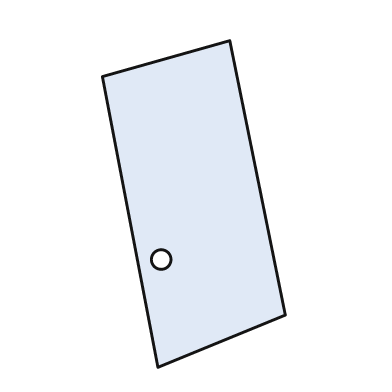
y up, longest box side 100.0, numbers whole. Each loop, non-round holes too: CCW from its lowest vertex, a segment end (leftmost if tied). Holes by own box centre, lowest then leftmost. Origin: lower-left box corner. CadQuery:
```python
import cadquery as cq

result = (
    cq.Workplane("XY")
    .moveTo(17.0, 0.0)
    .lineTo(56.0, 16.0)
    .lineTo(39.0, 100.0)
    .lineTo(0.0, 89.0)
    .close()
    .moveTo(18.0, 33.0)
    .circle(3.0)
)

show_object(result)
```